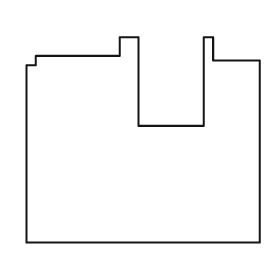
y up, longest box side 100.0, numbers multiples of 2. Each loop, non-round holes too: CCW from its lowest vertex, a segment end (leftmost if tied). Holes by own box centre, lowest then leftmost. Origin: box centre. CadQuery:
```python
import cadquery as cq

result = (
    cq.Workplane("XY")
    .moveTo(-50.0, -44.0)
    .lineTo(50.0, -44.0)
    .lineTo(50.0, 34.0)
    .lineTo(30.0, 34.0)
    .lineTo(30.0, 44.0)
    .lineTo(26.0, 44.0)
    .lineTo(26.0, 6.0)
    .lineTo(-2.0, 6.0)
    .lineTo(-2.0, 44.0)
    .lineTo(-10.0, 44.0)
    .lineTo(-10.0, 36.0)
    .lineTo(-46.0, 36.0)
    .lineTo(-46.0, 32.0)
    .lineTo(-50.0, 32.0)
    .close()
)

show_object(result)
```